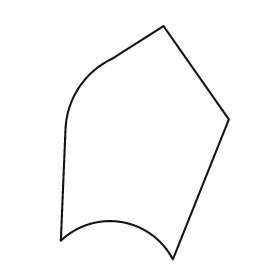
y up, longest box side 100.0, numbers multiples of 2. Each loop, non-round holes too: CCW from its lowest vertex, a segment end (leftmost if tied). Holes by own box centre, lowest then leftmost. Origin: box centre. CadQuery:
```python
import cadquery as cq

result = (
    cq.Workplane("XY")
    .moveTo(12.0, -50.0)
    .lineTo(36.0, 10.0)
    .lineTo(8.0, 50.0)
    .lineTo(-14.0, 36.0)
    .threePointArc((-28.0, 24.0), (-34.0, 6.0))
    .lineTo(-36.0, -42.0)
    .threePointArc((-10.0, -34.0), (12.0, -50.0))
    .close()
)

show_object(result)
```